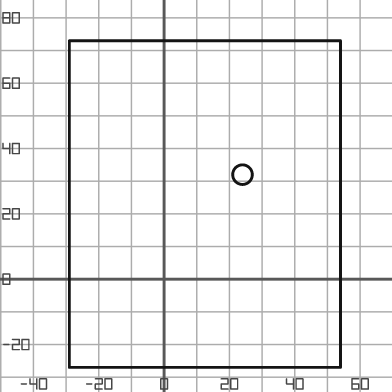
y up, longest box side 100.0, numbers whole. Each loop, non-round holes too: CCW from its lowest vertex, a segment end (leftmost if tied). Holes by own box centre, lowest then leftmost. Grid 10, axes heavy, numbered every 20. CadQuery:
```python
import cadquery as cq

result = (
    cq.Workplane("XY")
    .moveTo(-29.0, -27.0)
    .lineTo(54.0, -27.0)
    .lineTo(54.0, 73.0)
    .lineTo(-29.0, 73.0)
    .close()
    .moveTo(24.0, 32.0)
    .circle(3.0)
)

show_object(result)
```